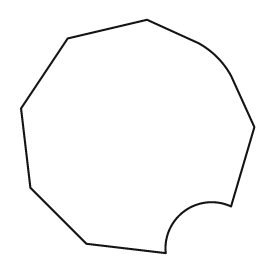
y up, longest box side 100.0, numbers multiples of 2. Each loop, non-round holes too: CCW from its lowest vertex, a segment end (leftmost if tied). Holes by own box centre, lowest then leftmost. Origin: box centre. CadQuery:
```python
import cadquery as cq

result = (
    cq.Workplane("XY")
    .moveTo(12.0, -50.0)
    .threePointArc((20.0, -32.0), (40.0, -30.0))
    .lineTo(50.0, 4.0)
    .lineTo(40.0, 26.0)
    .threePointArc((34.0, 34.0), (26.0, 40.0))
    .lineTo(4.0, 50.0)
    .lineTo(-30.0, 42.0)
    .lineTo(-50.0, 12.0)
    .lineTo(-46.0, -22.0)
    .lineTo(-22.0, -46.0)
    .close()
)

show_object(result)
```